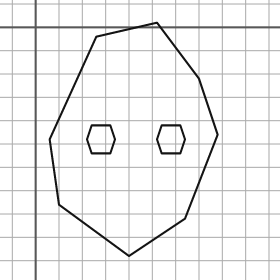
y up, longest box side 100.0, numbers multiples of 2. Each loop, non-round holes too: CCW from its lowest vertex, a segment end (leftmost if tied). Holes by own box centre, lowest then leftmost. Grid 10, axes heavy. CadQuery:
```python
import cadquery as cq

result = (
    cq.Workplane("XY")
    .moveTo(40.0, -98.0)
    .lineTo(64.0, -82.0)
    .lineTo(78.0, -46.0)
    .lineTo(70.0, -22.0)
    .lineTo(52.0, 2.0)
    .lineTo(26.0, -4.0)
    .lineTo(6.0, -48.0)
    .lineTo(10.0, -76.0)
    .close()
    .moveTo(24.0, -54.0)
    .lineTo(32.0, -54.0)
    .lineTo(34.0, -48.0)
    .lineTo(32.0, -42.0)
    .lineTo(24.0, -42.0)
    .lineTo(22.0, -48.0)
    .close()
    .moveTo(54.0, -54.0)
    .lineTo(62.0, -54.0)
    .lineTo(64.0, -48.0)
    .lineTo(62.0, -42.0)
    .lineTo(54.0, -42.0)
    .lineTo(52.0, -48.0)
    .close()
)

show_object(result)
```